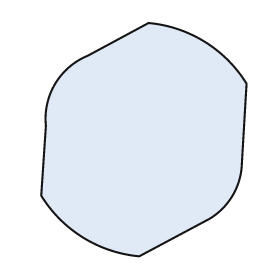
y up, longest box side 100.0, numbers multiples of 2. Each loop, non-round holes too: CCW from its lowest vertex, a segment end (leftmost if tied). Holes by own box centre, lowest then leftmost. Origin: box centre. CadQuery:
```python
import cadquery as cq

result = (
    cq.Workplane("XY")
    .moveTo(-2.0, -50.0)
    .lineTo(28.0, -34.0)
    .threePointArc((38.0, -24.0), (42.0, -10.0))
    .lineTo(44.0, 24.0)
    .threePointArc((26.0, 42.0), (2.0, 50.0))
    .lineTo(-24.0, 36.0)
    .threePointArc((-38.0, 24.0), (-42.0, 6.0))
    .lineTo(-44.0, -24.0)
    .threePointArc((-26.0, -42.0), (-2.0, -50.0))
    .close()
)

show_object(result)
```